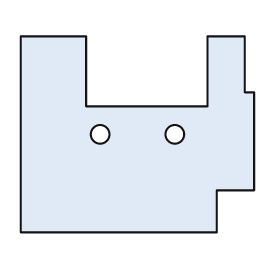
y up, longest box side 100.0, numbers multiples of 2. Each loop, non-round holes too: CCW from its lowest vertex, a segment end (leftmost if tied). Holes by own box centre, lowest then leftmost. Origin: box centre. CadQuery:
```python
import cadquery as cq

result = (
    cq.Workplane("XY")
    .moveTo(-50.0, -42.0)
    .lineTo(34.0, -42.0)
    .lineTo(34.0, -24.0)
    .lineTo(50.0, -24.0)
    .lineTo(50.0, 18.0)
    .lineTo(46.0, 18.0)
    .lineTo(46.0, 42.0)
    .lineTo(30.0, 42.0)
    .lineTo(30.0, 12.0)
    .lineTo(-22.0, 12.0)
    .lineTo(-22.0, 42.0)
    .lineTo(-50.0, 42.0)
    .close()
    .moveTo(-16.0, 0.0)
    .circle(4.0)
    .moveTo(16.0, 0.0)
    .circle(4.0)
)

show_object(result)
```